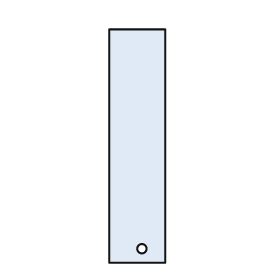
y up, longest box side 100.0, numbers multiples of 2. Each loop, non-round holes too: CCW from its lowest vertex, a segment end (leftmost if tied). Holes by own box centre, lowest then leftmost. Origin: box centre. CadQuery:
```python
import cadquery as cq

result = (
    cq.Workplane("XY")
    .moveTo(-12.0, -50.0)
    .lineTo(12.0, -50.0)
    .lineTo(12.0, 50.0)
    .lineTo(-12.0, 50.0)
    .close()
    .moveTo(2.0, -44.0)
    .circle(2.0)
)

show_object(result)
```